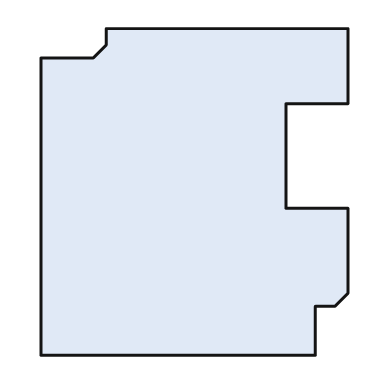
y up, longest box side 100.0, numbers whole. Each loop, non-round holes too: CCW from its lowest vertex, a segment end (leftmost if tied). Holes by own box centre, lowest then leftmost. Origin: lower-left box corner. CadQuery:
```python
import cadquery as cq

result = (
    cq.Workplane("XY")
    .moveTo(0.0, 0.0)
    .lineTo(84.0, 0.0)
    .lineTo(84.0, 15.0)
    .lineTo(90.0, 15.0)
    .lineTo(94.0, 19.0)
    .lineTo(94.0, 45.0)
    .lineTo(75.0, 45.0)
    .lineTo(75.0, 77.0)
    .lineTo(94.0, 77.0)
    .lineTo(94.0, 100.0)
    .lineTo(20.0, 100.0)
    .lineTo(20.0, 95.0)
    .lineTo(16.0, 91.0)
    .lineTo(0.0, 91.0)
    .close()
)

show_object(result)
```